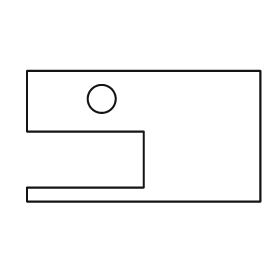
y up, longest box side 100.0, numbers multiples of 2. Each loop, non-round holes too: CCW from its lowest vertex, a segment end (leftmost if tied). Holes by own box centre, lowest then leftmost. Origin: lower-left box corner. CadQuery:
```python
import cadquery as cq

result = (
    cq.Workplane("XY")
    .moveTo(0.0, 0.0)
    .lineTo(100.0, 0.0)
    .lineTo(100.0, 56.0)
    .lineTo(0.0, 56.0)
    .lineTo(0.0, 30.0)
    .lineTo(50.0, 30.0)
    .lineTo(50.0, 6.0)
    .lineTo(0.0, 6.0)
    .close()
    .moveTo(32.0, 44.0)
    .circle(6.0)
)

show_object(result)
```